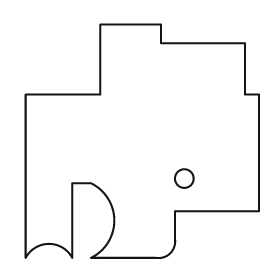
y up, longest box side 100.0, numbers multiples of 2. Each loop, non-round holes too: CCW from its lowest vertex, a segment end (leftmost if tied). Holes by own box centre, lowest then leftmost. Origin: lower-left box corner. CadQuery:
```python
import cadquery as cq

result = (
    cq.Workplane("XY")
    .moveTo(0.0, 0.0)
    .threePointArc((10.0, 6.0), (20.0, 0.0))
    .lineTo(20.0, 32.0)
    .lineTo(28.0, 32.0)
    .threePointArc((38.0, 16.0), (28.0, 0.0))
    .lineTo(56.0, 0.0)
    .threePointArc((62.0, 2.0), (64.0, 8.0))
    .lineTo(64.0, 20.0)
    .lineTo(100.0, 20.0)
    .lineTo(100.0, 70.0)
    .lineTo(94.0, 70.0)
    .lineTo(94.0, 92.0)
    .lineTo(58.0, 92.0)
    .lineTo(58.0, 100.0)
    .lineTo(32.0, 100.0)
    .lineTo(32.0, 70.0)
    .lineTo(0.0, 70.0)
    .close()
    .moveTo(68.0, 34.0)
    .circle(4.0)
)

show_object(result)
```